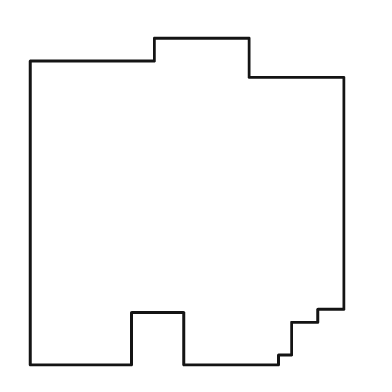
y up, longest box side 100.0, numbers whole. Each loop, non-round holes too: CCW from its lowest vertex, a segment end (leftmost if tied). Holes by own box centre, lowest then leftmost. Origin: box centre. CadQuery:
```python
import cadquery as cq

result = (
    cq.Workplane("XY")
    .moveTo(-48.0, -50.0)
    .lineTo(-17.0, -50.0)
    .lineTo(-17.0, -34.0)
    .lineTo(-1.0, -34.0)
    .lineTo(-1.0, -50.0)
    .lineTo(28.0, -50.0)
    .lineTo(28.0, -47.0)
    .lineTo(32.0, -47.0)
    .lineTo(32.0, -37.0)
    .lineTo(40.0, -37.0)
    .lineTo(40.0, -33.0)
    .lineTo(48.0, -33.0)
    .lineTo(48.0, 38.0)
    .lineTo(19.0, 38.0)
    .lineTo(19.0, 50.0)
    .lineTo(-10.0, 50.0)
    .lineTo(-10.0, 43.0)
    .lineTo(-48.0, 43.0)
    .close()
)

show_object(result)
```